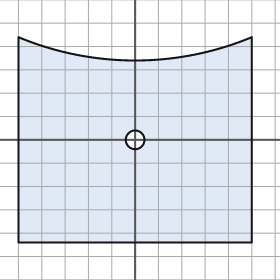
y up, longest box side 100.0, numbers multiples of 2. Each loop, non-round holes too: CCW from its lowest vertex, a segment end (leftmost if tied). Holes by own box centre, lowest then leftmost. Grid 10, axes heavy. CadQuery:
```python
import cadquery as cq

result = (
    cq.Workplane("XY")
    .moveTo(-50.0, -44.0)
    .lineTo(50.0, -44.0)
    .lineTo(50.0, 44.0)
    .threePointArc((0.0, 34.0), (-50.0, 44.0))
    .close()
    .moveTo(0.0, 0.0)
    .circle(4.0)
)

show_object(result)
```